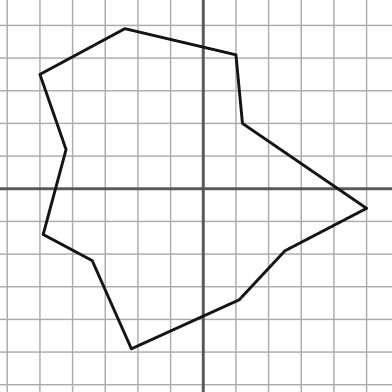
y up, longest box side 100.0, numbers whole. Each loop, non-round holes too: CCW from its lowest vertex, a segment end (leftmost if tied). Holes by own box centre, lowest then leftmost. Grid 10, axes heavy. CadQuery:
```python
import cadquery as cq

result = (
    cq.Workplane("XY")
    .moveTo(-22.0, -49.0)
    .lineTo(11.0, -34.0)
    .lineTo(25.0, -19.0)
    .lineTo(50.0, -6.0)
    .lineTo(12.0, 20.0)
    .lineTo(10.0, 41.0)
    .lineTo(-24.0, 49.0)
    .lineTo(-50.0, 35.0)
    .lineTo(-42.0, 12.0)
    .lineTo(-49.0, -14.0)
    .lineTo(-34.0, -22.0)
    .close()
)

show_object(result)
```